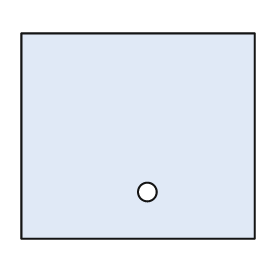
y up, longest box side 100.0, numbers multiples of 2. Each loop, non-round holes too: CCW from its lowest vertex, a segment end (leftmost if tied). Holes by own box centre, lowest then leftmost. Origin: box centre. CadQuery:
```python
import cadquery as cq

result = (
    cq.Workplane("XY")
    .moveTo(-50.0, -44.0)
    .lineTo(50.0, -44.0)
    .lineTo(50.0, 44.0)
    .lineTo(-50.0, 44.0)
    .close()
    .moveTo(4.0, -24.0)
    .circle(4.0)
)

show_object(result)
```